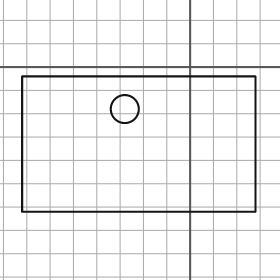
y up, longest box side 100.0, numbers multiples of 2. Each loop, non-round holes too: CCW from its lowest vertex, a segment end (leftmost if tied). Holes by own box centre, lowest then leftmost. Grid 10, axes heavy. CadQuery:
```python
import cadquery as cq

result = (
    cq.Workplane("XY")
    .moveTo(-72.0, -62.0)
    .lineTo(28.0, -62.0)
    .lineTo(28.0, -4.0)
    .lineTo(-72.0, -4.0)
    .close()
    .moveTo(-28.0, -18.0)
    .circle(6.0)
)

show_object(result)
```